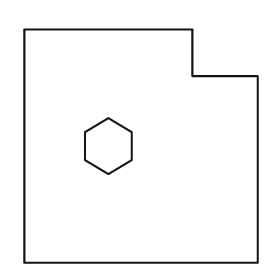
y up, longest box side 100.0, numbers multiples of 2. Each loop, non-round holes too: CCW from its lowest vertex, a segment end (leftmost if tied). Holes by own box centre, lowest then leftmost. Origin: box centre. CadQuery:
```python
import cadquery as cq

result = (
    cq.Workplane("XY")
    .moveTo(-50.0, -50.0)
    .lineTo(50.0, -50.0)
    .lineTo(50.0, 30.0)
    .lineTo(22.0, 30.0)
    .lineTo(22.0, 50.0)
    .lineTo(-50.0, 50.0)
    .close()
    .moveTo(-14.0, -12.0)
    .lineTo(-4.0, -6.0)
    .lineTo(-4.0, 6.0)
    .lineTo(-14.0, 12.0)
    .lineTo(-24.0, 6.0)
    .lineTo(-24.0, -6.0)
    .close()
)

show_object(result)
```